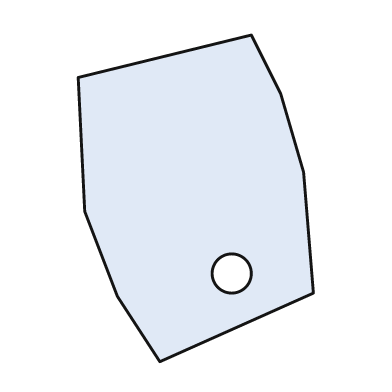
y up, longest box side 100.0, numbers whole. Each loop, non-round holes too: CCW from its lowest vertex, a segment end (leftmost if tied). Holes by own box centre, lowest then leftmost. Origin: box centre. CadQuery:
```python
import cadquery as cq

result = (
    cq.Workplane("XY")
    .moveTo(-11.0, -50.0)
    .lineTo(36.0, -29.0)
    .lineTo(33.0, 8.0)
    .lineTo(26.0, 32.0)
    .lineTo(17.0, 50.0)
    .lineTo(-36.0, 37.0)
    .lineTo(-34.0, -4.0)
    .lineTo(-24.0, -30.0)
    .close()
    .moveTo(11.0, -23.0)
    .circle(6.0)
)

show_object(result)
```